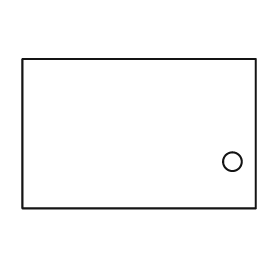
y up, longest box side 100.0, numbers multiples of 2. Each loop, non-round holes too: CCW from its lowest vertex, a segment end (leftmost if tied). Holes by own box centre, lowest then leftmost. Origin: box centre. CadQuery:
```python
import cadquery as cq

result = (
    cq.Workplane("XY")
    .moveTo(-50.0, -32.0)
    .lineTo(50.0, -32.0)
    .lineTo(50.0, 32.0)
    .lineTo(-50.0, 32.0)
    .close()
    .moveTo(40.0, -12.0)
    .circle(4.0)
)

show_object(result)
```